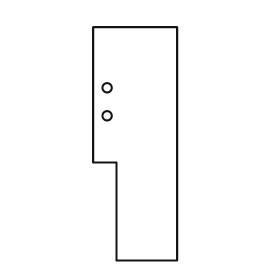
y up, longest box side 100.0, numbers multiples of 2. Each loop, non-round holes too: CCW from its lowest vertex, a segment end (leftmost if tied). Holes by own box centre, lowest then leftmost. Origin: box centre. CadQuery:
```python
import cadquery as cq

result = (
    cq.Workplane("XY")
    .moveTo(-8.0, -50.0)
    .lineTo(18.0, -50.0)
    .lineTo(18.0, 50.0)
    .lineTo(-18.0, 50.0)
    .lineTo(-18.0, -8.0)
    .lineTo(-8.0, -8.0)
    .close()
    .moveTo(-12.0, 12.0)
    .circle(2.0)
    .moveTo(-12.0, 24.0)
    .circle(2.0)
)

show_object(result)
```